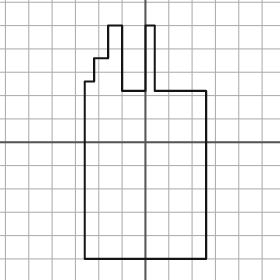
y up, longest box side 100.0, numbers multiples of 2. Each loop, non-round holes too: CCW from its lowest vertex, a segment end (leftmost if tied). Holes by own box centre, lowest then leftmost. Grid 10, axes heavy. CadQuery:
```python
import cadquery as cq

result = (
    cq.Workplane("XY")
    .moveTo(-26.0, -50.0)
    .lineTo(26.0, -50.0)
    .lineTo(26.0, 22.0)
    .lineTo(4.0, 22.0)
    .lineTo(4.0, 50.0)
    .lineTo(0.0, 50.0)
    .lineTo(0.0, 22.0)
    .lineTo(-10.0, 22.0)
    .lineTo(-10.0, 50.0)
    .lineTo(-16.0, 50.0)
    .lineTo(-16.0, 36.0)
    .lineTo(-22.0, 36.0)
    .lineTo(-22.0, 26.0)
    .lineTo(-26.0, 26.0)
    .close()
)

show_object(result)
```